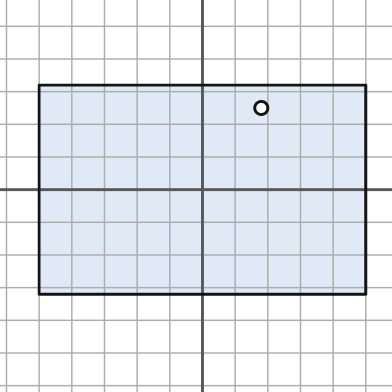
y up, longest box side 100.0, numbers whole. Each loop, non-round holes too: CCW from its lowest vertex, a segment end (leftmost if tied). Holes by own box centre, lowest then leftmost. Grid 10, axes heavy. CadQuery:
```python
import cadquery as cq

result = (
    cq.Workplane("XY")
    .moveTo(-50.0, -32.0)
    .lineTo(50.0, -32.0)
    .lineTo(50.0, 32.0)
    .lineTo(-50.0, 32.0)
    .close()
    .moveTo(18.0, 25.0)
    .circle(2.0)
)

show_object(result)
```